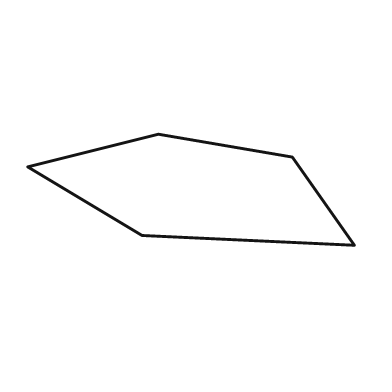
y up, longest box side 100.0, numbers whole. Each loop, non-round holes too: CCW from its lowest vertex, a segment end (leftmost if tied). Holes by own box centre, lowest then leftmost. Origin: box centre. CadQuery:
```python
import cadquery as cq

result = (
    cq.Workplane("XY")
    .moveTo(50.0, -17.0)
    .lineTo(31.0, 10.0)
    .lineTo(-10.0, 17.0)
    .lineTo(-50.0, 7.0)
    .lineTo(-15.0, -14.0)
    .close()
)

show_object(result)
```